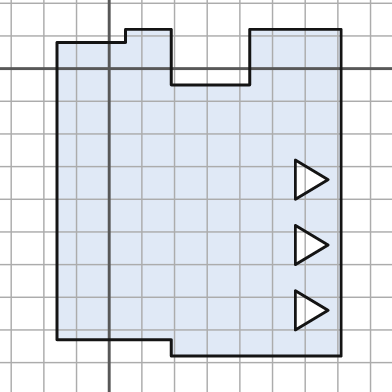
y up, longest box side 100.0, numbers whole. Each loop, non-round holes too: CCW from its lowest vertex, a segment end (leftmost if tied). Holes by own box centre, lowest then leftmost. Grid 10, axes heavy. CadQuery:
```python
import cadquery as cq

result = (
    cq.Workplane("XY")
    .moveTo(19.0, -88.0)
    .lineTo(71.0, -88.0)
    .lineTo(71.0, 12.0)
    .lineTo(43.0, 12.0)
    .lineTo(43.0, -5.0)
    .lineTo(19.0, -5.0)
    .lineTo(19.0, 12.0)
    .lineTo(5.0, 12.0)
    .lineTo(5.0, 8.0)
    .lineTo(-16.0, 8.0)
    .lineTo(-16.0, -83.0)
    .lineTo(19.0, -83.0)
    .close()
    .moveTo(57.0, -80.0)
    .lineTo(67.0, -74.0)
    .lineTo(57.0, -68.0)
    .close()
    .moveTo(57.0, -60.0)
    .lineTo(67.0, -54.0)
    .lineTo(57.0, -48.0)
    .close()
    .moveTo(57.0, -40.0)
    .lineTo(67.0, -34.0)
    .lineTo(57.0, -28.0)
    .close()
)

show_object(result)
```